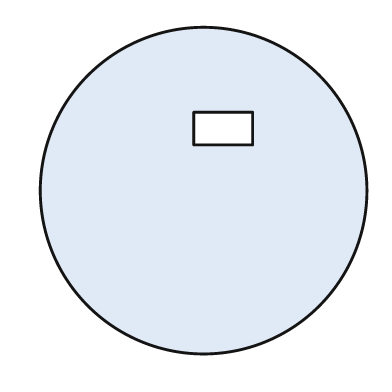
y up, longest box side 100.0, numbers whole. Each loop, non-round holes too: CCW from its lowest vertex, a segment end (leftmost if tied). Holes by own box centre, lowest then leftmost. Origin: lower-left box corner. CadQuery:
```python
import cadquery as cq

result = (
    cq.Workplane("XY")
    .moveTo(50.0, 50.0)
    .circle(50.0)
    .moveTo(47.0, 64.0)
    .lineTo(65.0, 64.0)
    .lineTo(65.0, 74.0)
    .lineTo(47.0, 74.0)
    .close()
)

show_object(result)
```